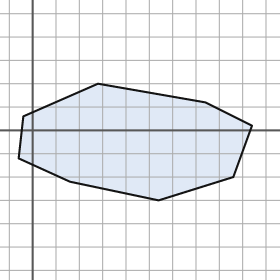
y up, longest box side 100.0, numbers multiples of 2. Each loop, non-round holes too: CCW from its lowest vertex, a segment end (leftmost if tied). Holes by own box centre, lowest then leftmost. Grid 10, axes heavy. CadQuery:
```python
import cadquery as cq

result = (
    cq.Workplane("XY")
    .moveTo(54.0, -30.0)
    .lineTo(86.0, -20.0)
    .lineTo(94.0, 2.0)
    .lineTo(74.0, 12.0)
    .lineTo(28.0, 20.0)
    .lineTo(-4.0, 6.0)
    .lineTo(-6.0, -12.0)
    .lineTo(16.0, -22.0)
    .close()
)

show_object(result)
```